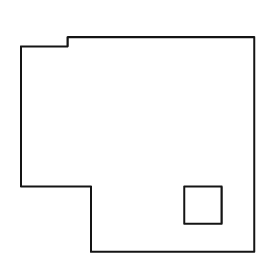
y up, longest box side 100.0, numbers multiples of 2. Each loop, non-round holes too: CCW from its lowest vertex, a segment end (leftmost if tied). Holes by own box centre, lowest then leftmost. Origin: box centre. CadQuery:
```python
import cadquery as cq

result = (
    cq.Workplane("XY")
    .moveTo(-20.0, -46.0)
    .lineTo(50.0, -46.0)
    .lineTo(50.0, 46.0)
    .lineTo(-30.0, 46.0)
    .lineTo(-30.0, 42.0)
    .lineTo(-50.0, 42.0)
    .lineTo(-50.0, -18.0)
    .lineTo(-20.0, -18.0)
    .close()
    .moveTo(20.0, -34.0)
    .lineTo(36.0, -34.0)
    .lineTo(36.0, -18.0)
    .lineTo(20.0, -18.0)
    .close()
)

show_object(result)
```